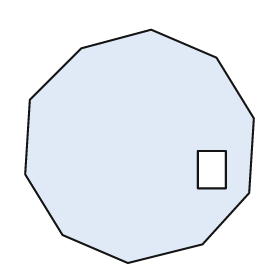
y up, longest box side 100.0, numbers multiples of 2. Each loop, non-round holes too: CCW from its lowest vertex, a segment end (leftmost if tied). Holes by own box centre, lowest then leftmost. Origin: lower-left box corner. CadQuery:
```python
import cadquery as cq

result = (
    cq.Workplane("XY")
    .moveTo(44.0, 0.0)
    .lineTo(76.0, 8.0)
    .lineTo(96.0, 30.0)
    .lineTo(98.0, 62.0)
    .lineTo(82.0, 88.0)
    .lineTo(54.0, 100.0)
    .lineTo(24.0, 92.0)
    .lineTo(2.0, 70.0)
    .lineTo(0.0, 38.0)
    .lineTo(16.0, 12.0)
    .close()
    .moveTo(74.0, 32.0)
    .lineTo(86.0, 32.0)
    .lineTo(86.0, 48.0)
    .lineTo(74.0, 48.0)
    .close()
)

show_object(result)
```